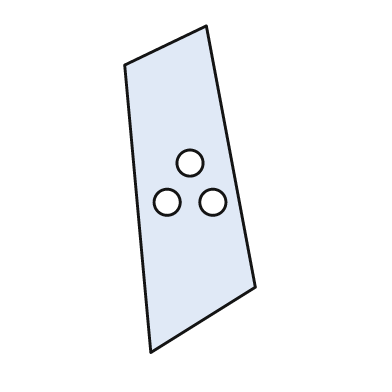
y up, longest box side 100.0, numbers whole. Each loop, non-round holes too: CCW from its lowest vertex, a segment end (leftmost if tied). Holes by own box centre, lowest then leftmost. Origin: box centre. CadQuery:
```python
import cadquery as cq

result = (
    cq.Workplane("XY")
    .moveTo(-12.0, -50.0)
    .lineTo(20.0, -30.0)
    .lineTo(5.0, 50.0)
    .lineTo(-20.0, 38.0)
    .close()
    .moveTo(-7.0, -4.0)
    .circle(4.0)
    .moveTo(7.0, -4.0)
    .circle(4.0)
    .moveTo(0.0, 8.0)
    .circle(4.0)
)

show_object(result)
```